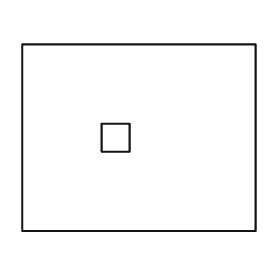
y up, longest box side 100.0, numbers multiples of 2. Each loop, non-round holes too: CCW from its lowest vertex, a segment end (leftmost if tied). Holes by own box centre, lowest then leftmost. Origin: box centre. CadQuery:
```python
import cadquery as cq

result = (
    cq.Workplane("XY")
    .moveTo(-50.0, -40.0)
    .lineTo(50.0, -40.0)
    .lineTo(50.0, 40.0)
    .lineTo(-50.0, 40.0)
    .close()
    .moveTo(-16.0, -6.0)
    .lineTo(-4.0, -6.0)
    .lineTo(-4.0, 6.0)
    .lineTo(-16.0, 6.0)
    .close()
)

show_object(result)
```